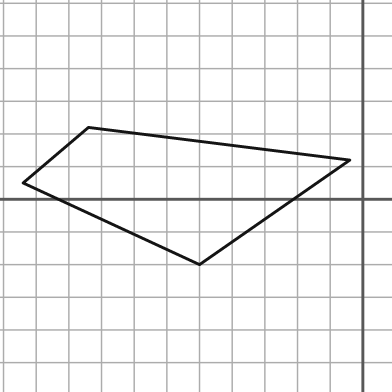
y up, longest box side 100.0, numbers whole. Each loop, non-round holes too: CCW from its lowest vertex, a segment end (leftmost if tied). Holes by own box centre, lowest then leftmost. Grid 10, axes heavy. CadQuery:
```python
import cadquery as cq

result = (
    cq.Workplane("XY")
    .moveTo(-50.0, -20.0)
    .lineTo(-4.0, 12.0)
    .lineTo(-84.0, 22.0)
    .lineTo(-104.0, 5.0)
    .close()
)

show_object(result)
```